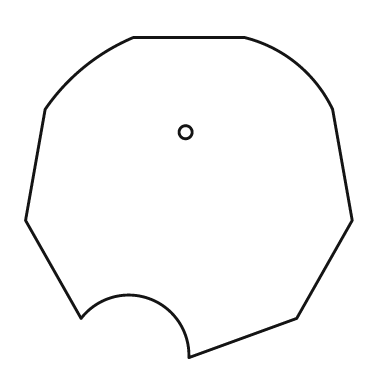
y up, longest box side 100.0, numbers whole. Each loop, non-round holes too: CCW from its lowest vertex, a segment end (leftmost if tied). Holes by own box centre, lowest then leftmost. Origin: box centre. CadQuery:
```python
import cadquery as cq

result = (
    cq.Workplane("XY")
    .moveTo(0.0, -49.0)
    .lineTo(33.0, -37.0)
    .lineTo(50.0, -7.0)
    .lineTo(44.0, 27.0)
    .threePointArc((33.0, 41.0), (17.0, 49.0))
    .lineTo(-17.0, 49.0)
    .threePointArc((-32.0, 40.0), (-44.0, 27.0))
    .lineTo(-50.0, -7.0)
    .lineTo(-33.0, -37.0)
    .threePointArc((-12.0, -31.0), (0.0, -49.0))
    .close()
    .moveTo(-1.0, 20.0)
    .circle(2.0)
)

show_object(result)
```